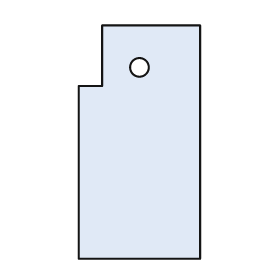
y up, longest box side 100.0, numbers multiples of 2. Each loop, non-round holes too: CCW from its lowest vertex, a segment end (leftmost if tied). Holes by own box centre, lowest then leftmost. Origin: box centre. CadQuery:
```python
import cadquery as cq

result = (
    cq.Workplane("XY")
    .moveTo(-26.0, -50.0)
    .lineTo(26.0, -50.0)
    .lineTo(26.0, 50.0)
    .lineTo(-16.0, 50.0)
    .lineTo(-16.0, 24.0)
    .lineTo(-26.0, 24.0)
    .close()
    .moveTo(0.0, 32.0)
    .circle(4.0)
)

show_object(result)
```